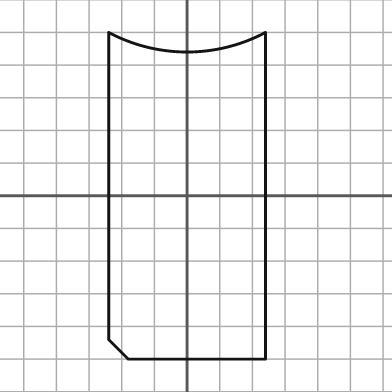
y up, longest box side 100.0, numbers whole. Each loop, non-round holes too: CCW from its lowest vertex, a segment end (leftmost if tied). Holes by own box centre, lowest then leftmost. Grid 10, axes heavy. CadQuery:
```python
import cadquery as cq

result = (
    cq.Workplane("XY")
    .moveTo(-18.0, -50.0)
    .lineTo(24.0, -50.0)
    .lineTo(24.0, 50.0)
    .threePointArc((0.0, 44.0), (-24.0, 50.0))
    .lineTo(-24.0, -44.0)
    .close()
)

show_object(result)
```